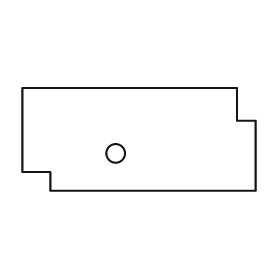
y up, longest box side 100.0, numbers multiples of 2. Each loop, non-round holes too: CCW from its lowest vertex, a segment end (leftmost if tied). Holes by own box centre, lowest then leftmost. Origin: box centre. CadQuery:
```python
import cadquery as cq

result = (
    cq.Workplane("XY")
    .moveTo(-38.0, -22.0)
    .lineTo(50.0, -22.0)
    .lineTo(50.0, 8.0)
    .lineTo(42.0, 8.0)
    .lineTo(42.0, 22.0)
    .lineTo(-50.0, 22.0)
    .lineTo(-50.0, -14.0)
    .lineTo(-38.0, -14.0)
    .close()
    .moveTo(-10.0, -6.0)
    .circle(4.0)
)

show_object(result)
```